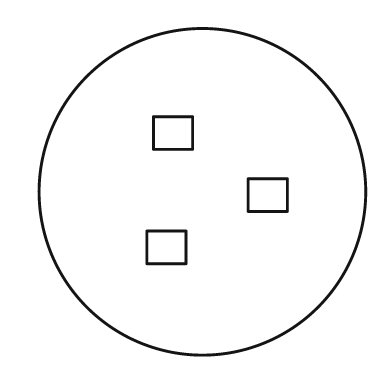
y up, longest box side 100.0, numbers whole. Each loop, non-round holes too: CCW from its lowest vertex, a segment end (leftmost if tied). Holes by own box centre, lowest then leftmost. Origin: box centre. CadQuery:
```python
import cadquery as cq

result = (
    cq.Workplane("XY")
    .moveTo(0.0, 0.0)
    .circle(50.0)
    .moveTo(-17.0, -22.0)
    .lineTo(-5.0, -22.0)
    .lineTo(-5.0, -12.0)
    .lineTo(-17.0, -12.0)
    .close()
    .moveTo(14.0, -6.0)
    .lineTo(26.0, -6.0)
    .lineTo(26.0, 4.0)
    .lineTo(14.0, 4.0)
    .close()
    .moveTo(-15.0, 13.0)
    .lineTo(-3.0, 13.0)
    .lineTo(-3.0, 23.0)
    .lineTo(-15.0, 23.0)
    .close()
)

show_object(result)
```